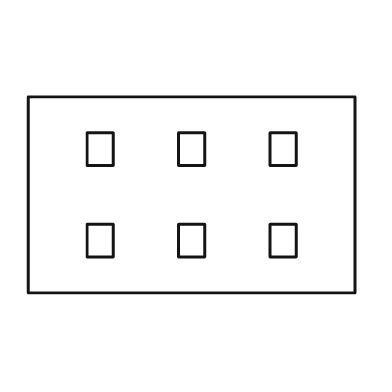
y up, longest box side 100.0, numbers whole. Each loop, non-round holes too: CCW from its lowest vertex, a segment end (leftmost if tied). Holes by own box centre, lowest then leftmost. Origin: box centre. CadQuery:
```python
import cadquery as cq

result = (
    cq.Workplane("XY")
    .moveTo(-50.0, -30.0)
    .lineTo(50.0, -30.0)
    .lineTo(50.0, 30.0)
    .lineTo(-50.0, 30.0)
    .close()
    .moveTo(-32.0, -19.0)
    .lineTo(-24.0, -19.0)
    .lineTo(-24.0, -9.0)
    .lineTo(-32.0, -9.0)
    .close()
    .moveTo(-4.0, -19.0)
    .lineTo(4.0, -19.0)
    .lineTo(4.0, -9.0)
    .lineTo(-4.0, -9.0)
    .close()
    .moveTo(24.0, -19.0)
    .lineTo(32.0, -19.0)
    .lineTo(32.0, -9.0)
    .lineTo(24.0, -9.0)
    .close()
    .moveTo(-32.0, 9.0)
    .lineTo(-24.0, 9.0)
    .lineTo(-24.0, 19.0)
    .lineTo(-32.0, 19.0)
    .close()
    .moveTo(-4.0, 9.0)
    .lineTo(4.0, 9.0)
    .lineTo(4.0, 19.0)
    .lineTo(-4.0, 19.0)
    .close()
    .moveTo(24.0, 9.0)
    .lineTo(32.0, 9.0)
    .lineTo(32.0, 19.0)
    .lineTo(24.0, 19.0)
    .close()
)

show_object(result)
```